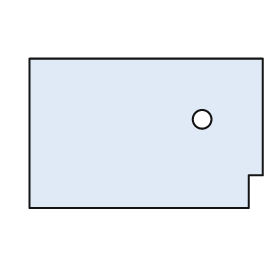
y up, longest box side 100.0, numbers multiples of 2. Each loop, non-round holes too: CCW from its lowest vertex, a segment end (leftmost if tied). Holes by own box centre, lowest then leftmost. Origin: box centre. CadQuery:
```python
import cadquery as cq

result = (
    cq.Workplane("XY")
    .moveTo(-50.0, -32.0)
    .lineTo(44.0, -32.0)
    .lineTo(44.0, -18.0)
    .lineTo(50.0, -18.0)
    .lineTo(50.0, 32.0)
    .lineTo(-50.0, 32.0)
    .close()
    .moveTo(24.0, 6.0)
    .circle(4.0)
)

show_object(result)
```